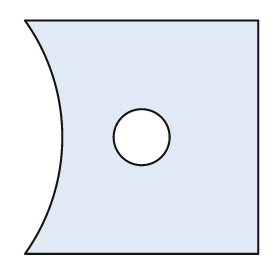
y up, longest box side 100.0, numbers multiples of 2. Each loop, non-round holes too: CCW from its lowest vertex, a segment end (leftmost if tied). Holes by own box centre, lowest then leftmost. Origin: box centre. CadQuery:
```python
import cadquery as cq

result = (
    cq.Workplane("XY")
    .moveTo(-50.0, -50.0)
    .lineTo(50.0, -50.0)
    .lineTo(50.0, 50.0)
    .lineTo(-50.0, 50.0)
    .threePointArc((-34.0, 0.0), (-50.0, -50.0))
    .close()
    .moveTo(0.0, 0.0)
    .circle(12.0)
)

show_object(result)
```